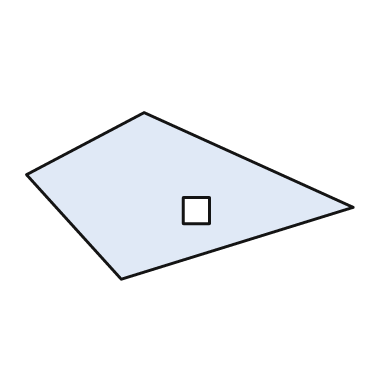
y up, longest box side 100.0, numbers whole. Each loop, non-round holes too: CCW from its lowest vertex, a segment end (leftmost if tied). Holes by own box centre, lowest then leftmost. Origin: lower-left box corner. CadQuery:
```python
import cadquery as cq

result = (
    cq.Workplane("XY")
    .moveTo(29.0, 0.0)
    .lineTo(100.0, 22.0)
    .lineTo(36.0, 51.0)
    .lineTo(0.0, 32.0)
    .close()
    .moveTo(48.0, 17.0)
    .lineTo(56.0, 17.0)
    .lineTo(56.0, 25.0)
    .lineTo(48.0, 25.0)
    .close()
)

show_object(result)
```